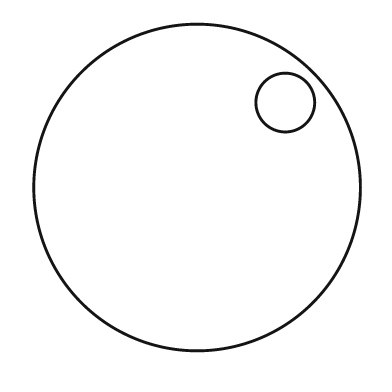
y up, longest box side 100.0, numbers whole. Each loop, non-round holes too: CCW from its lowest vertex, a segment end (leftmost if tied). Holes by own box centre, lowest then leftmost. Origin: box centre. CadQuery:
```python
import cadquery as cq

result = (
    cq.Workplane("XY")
    .moveTo(0.0, 0.0)
    .circle(50.0)
    .moveTo(27.0, 26.0)
    .circle(9.0)
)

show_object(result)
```